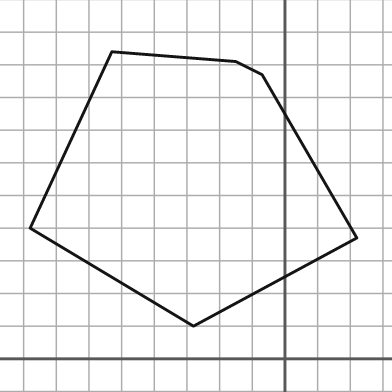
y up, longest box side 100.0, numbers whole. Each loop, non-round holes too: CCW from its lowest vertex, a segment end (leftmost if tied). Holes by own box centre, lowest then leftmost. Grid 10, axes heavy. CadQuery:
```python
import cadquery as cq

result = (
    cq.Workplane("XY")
    .moveTo(-28.0, 10.0)
    .lineTo(22.0, 37.0)
    .lineTo(-7.0, 87.0)
    .lineTo(-15.0, 91.0)
    .lineTo(-53.0, 94.0)
    .lineTo(-78.0, 40.0)
    .close()
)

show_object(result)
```